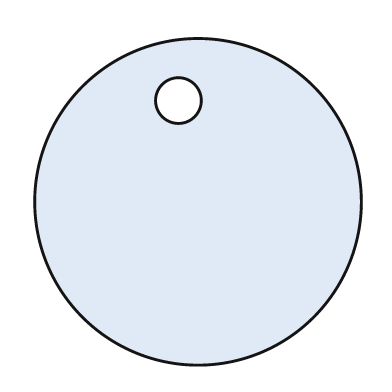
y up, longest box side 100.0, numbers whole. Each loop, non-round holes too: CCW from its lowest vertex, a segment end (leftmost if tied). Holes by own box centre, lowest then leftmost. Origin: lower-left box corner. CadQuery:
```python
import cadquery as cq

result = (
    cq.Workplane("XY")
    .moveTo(50.0, 50.0)
    .circle(50.0)
    .moveTo(44.0, 81.0)
    .circle(7.0)
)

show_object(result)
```